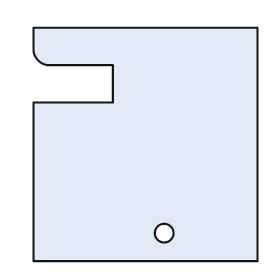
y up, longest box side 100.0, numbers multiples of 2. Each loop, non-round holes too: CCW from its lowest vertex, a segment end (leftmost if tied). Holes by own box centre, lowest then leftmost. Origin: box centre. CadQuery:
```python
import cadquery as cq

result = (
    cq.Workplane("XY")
    .moveTo(-48.0, -50.0)
    .lineTo(48.0, -50.0)
    .lineTo(48.0, 50.0)
    .lineTo(-48.0, 50.0)
    .lineTo(-48.0, 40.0)
    .threePointArc((-46.0, 36.0), (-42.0, 34.0))
    .lineTo(-14.0, 34.0)
    .lineTo(-14.0, 18.0)
    .lineTo(-48.0, 18.0)
    .close()
    .moveTo(8.0, -38.0)
    .circle(4.0)
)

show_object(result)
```